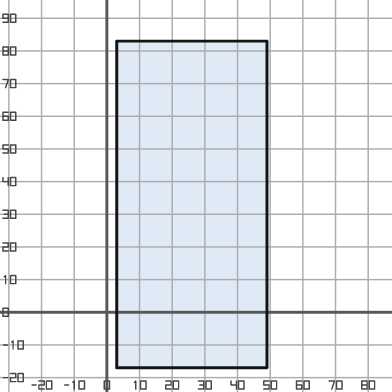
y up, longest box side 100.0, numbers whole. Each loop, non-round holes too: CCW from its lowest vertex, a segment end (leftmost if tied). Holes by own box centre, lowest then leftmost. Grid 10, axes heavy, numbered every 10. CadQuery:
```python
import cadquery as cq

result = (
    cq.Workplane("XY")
    .moveTo(3.0, -17.0)
    .lineTo(49.0, -17.0)
    .lineTo(49.0, 83.0)
    .lineTo(3.0, 83.0)
    .close()
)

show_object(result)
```